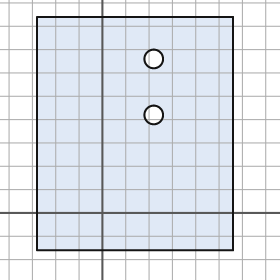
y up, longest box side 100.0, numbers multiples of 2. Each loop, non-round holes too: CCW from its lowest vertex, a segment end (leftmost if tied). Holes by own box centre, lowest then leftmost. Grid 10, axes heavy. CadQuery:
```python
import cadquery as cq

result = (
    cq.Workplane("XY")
    .moveTo(-28.0, -16.0)
    .lineTo(56.0, -16.0)
    .lineTo(56.0, 84.0)
    .lineTo(-28.0, 84.0)
    .close()
    .moveTo(22.0, 42.0)
    .circle(4.0)
    .moveTo(22.0, 66.0)
    .circle(4.0)
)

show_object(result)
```